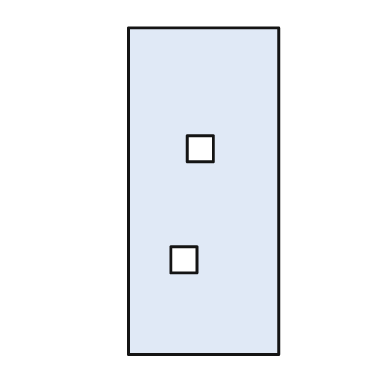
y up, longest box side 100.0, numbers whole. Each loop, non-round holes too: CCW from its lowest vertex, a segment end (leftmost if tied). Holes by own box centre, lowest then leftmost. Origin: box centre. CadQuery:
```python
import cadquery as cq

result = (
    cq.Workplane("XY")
    .moveTo(-23.0, -50.0)
    .lineTo(23.0, -50.0)
    .lineTo(23.0, 50.0)
    .lineTo(-23.0, 50.0)
    .close()
    .moveTo(-10.0, -25.0)
    .lineTo(-2.0, -25.0)
    .lineTo(-2.0, -17.0)
    .lineTo(-10.0, -17.0)
    .close()
    .moveTo(-5.0, 9.0)
    .lineTo(3.0, 9.0)
    .lineTo(3.0, 17.0)
    .lineTo(-5.0, 17.0)
    .close()
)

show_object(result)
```